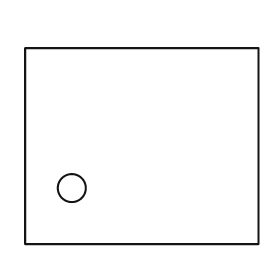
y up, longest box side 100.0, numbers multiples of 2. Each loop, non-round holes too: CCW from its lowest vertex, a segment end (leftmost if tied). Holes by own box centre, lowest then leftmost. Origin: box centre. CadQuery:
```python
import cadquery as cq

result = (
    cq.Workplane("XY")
    .moveTo(-50.0, -42.0)
    .lineTo(50.0, -42.0)
    .lineTo(50.0, 42.0)
    .lineTo(-50.0, 42.0)
    .close()
    .moveTo(-30.0, -18.0)
    .circle(6.0)
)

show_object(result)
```